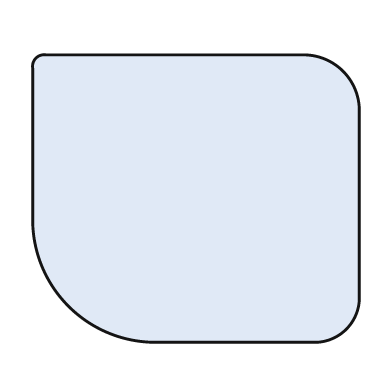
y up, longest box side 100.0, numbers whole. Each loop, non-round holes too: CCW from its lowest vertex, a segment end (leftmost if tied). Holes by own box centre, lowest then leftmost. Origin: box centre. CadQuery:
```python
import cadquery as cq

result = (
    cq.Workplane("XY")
    .moveTo(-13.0, -44.0)
    .lineTo(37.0, -44.0)
    .threePointArc((46.0, -40.0), (50.0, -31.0))
    .lineTo(50.0, 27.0)
    .threePointArc((45.0, 39.0), (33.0, 44.0))
    .lineTo(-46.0, 44.0)
    .threePointArc((-49.0, 43.0), (-50.0, 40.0))
    .lineTo(-50.0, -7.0)
    .threePointArc((-39.0, -33.0), (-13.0, -44.0))
    .close()
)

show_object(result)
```